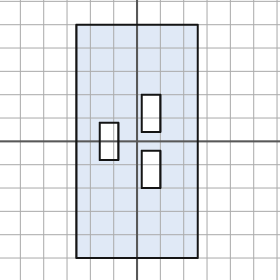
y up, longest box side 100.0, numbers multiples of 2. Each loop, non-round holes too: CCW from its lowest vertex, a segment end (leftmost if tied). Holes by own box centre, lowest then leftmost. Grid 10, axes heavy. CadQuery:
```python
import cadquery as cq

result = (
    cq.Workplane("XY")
    .moveTo(-26.0, -50.0)
    .lineTo(26.0, -50.0)
    .lineTo(26.0, 50.0)
    .lineTo(-26.0, 50.0)
    .close()
    .moveTo(2.0, -20.0)
    .lineTo(10.0, -20.0)
    .lineTo(10.0, -4.0)
    .lineTo(2.0, -4.0)
    .close()
    .moveTo(-16.0, -8.0)
    .lineTo(-8.0, -8.0)
    .lineTo(-8.0, 8.0)
    .lineTo(-16.0, 8.0)
    .close()
    .moveTo(2.0, 4.0)
    .lineTo(10.0, 4.0)
    .lineTo(10.0, 20.0)
    .lineTo(2.0, 20.0)
    .close()
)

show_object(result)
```